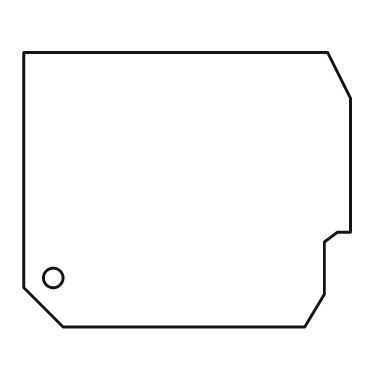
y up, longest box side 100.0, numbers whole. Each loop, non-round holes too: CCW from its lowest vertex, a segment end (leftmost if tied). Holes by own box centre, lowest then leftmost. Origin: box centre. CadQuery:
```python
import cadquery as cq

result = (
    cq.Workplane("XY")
    .moveTo(-38.0, -42.0)
    .lineTo(36.0, -42.0)
    .lineTo(42.0, -32.0)
    .lineTo(42.0, -16.0)
    .lineTo(46.0, -13.0)
    .lineTo(50.0, -13.0)
    .lineTo(50.0, 28.0)
    .lineTo(43.0, 42.0)
    .lineTo(-50.0, 42.0)
    .lineTo(-50.0, -30.0)
    .close()
    .moveTo(-41.0, -27.0)
    .circle(3.0)
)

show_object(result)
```